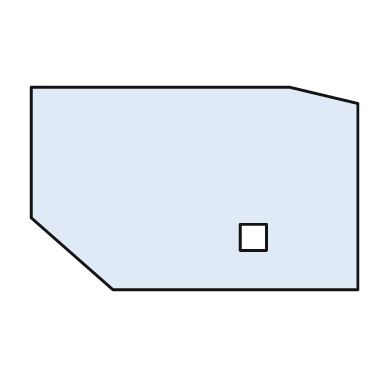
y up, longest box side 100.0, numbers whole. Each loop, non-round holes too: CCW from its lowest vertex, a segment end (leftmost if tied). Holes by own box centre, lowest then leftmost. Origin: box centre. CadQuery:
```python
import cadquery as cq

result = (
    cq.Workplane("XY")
    .moveTo(-25.0, -31.0)
    .lineTo(50.0, -31.0)
    .lineTo(50.0, 26.0)
    .lineTo(29.0, 31.0)
    .lineTo(-50.0, 31.0)
    .lineTo(-50.0, -9.0)
    .close()
    .moveTo(14.0, -19.0)
    .lineTo(22.0, -19.0)
    .lineTo(22.0, -11.0)
    .lineTo(14.0, -11.0)
    .close()
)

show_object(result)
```